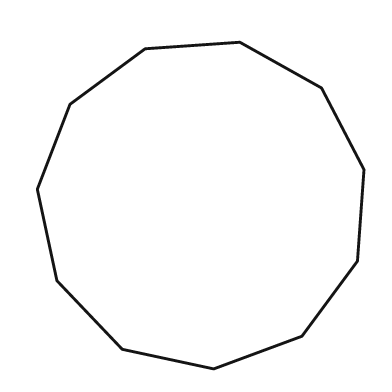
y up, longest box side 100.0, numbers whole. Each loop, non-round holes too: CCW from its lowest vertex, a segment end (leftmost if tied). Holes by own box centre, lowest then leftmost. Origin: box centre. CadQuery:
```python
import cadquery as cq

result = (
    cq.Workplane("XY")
    .moveTo(4.0, -50.0)
    .lineTo(31.0, -40.0)
    .lineTo(48.0, -17.0)
    .lineTo(50.0, 11.0)
    .lineTo(37.0, 36.0)
    .lineTo(12.0, 50.0)
    .lineTo(-17.0, 48.0)
    .lineTo(-40.0, 31.0)
    .lineTo(-50.0, 5.0)
    .lineTo(-44.0, -23.0)
    .lineTo(-24.0, -44.0)
    .close()
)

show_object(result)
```